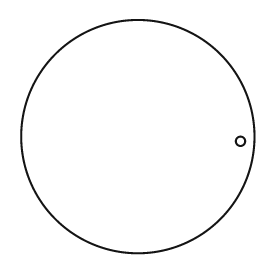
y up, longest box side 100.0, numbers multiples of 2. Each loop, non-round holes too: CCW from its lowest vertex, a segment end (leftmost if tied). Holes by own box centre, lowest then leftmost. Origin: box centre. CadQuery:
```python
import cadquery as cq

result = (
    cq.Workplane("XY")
    .moveTo(0.0, 0.0)
    .circle(50.0)
    .moveTo(44.0, -2.0)
    .circle(2.0)
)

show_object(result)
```